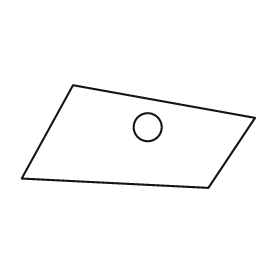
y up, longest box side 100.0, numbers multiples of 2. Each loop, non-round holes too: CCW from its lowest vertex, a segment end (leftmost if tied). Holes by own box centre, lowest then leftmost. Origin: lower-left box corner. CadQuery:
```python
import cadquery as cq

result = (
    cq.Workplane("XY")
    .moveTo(80.0, 0.0)
    .lineTo(100.0, 30.0)
    .lineTo(22.0, 44.0)
    .lineTo(0.0, 4.0)
    .close()
    .moveTo(54.0, 26.0)
    .circle(6.0)
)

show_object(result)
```